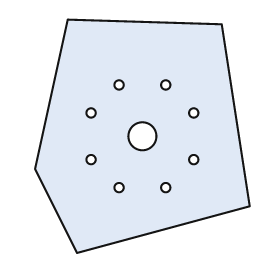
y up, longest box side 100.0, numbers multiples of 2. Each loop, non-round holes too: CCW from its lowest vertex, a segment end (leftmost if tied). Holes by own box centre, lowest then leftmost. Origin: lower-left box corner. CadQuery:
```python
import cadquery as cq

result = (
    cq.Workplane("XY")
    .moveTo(18.0, 0.0)
    .lineTo(92.0, 20.0)
    .lineTo(80.0, 98.0)
    .lineTo(14.0, 100.0)
    .lineTo(0.0, 36.0)
    .close()
    .moveTo(36.0, 28.0)
    .circle(2.0)
    .moveTo(56.0, 28.0)
    .circle(2.0)
    .moveTo(24.0, 40.0)
    .circle(2.0)
    .moveTo(68.0, 40.0)
    .circle(2.0)
    .moveTo(46.0, 50.0)
    .circle(6.0)
    .moveTo(24.0, 60.0)
    .circle(2.0)
    .moveTo(68.0, 60.0)
    .circle(2.0)
    .moveTo(36.0, 72.0)
    .circle(2.0)
    .moveTo(56.0, 72.0)
    .circle(2.0)
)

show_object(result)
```